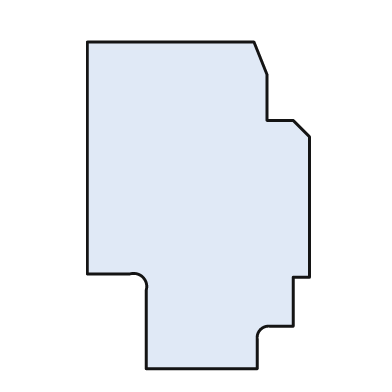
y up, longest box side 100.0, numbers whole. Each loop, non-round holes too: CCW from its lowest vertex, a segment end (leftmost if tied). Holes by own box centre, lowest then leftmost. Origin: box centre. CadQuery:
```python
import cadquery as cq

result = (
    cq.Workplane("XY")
    .moveTo(-16.0, -50.0)
    .lineTo(18.0, -50.0)
    .lineTo(18.0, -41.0)
    .threePointArc((19.0, -38.0), (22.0, -37.0))
    .lineTo(29.0, -37.0)
    .lineTo(29.0, -22.0)
    .lineTo(34.0, -22.0)
    .lineTo(34.0, 21.0)
    .lineTo(29.0, 26.0)
    .lineTo(21.0, 26.0)
    .lineTo(21.0, 40.0)
    .lineTo(17.0, 50.0)
    .lineTo(-34.0, 50.0)
    .lineTo(-34.0, -21.0)
    .lineTo(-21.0, -21.0)
    .threePointArc((-17.0, -22.0), (-16.0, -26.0))
    .close()
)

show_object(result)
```